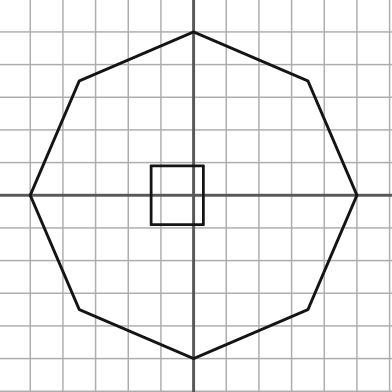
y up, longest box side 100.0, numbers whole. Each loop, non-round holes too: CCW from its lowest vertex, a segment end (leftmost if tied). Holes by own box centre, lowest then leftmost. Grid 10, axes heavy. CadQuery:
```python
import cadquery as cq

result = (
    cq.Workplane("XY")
    .moveTo(0.0, -50.0)
    .lineTo(35.0, -35.0)
    .lineTo(50.0, 0.0)
    .lineTo(35.0, 35.0)
    .lineTo(0.0, 50.0)
    .lineTo(-35.0, 35.0)
    .lineTo(-50.0, 0.0)
    .lineTo(-35.0, -35.0)
    .close()
    .moveTo(-13.0, -9.0)
    .lineTo(3.0, -9.0)
    .lineTo(3.0, 9.0)
    .lineTo(-13.0, 9.0)
    .close()
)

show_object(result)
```